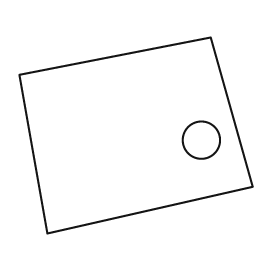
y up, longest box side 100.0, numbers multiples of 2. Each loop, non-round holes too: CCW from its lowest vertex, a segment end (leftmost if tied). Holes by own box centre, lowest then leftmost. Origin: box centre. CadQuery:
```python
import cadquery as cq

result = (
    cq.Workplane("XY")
    .moveTo(-38.0, -42.0)
    .lineTo(50.0, -22.0)
    .lineTo(32.0, 42.0)
    .lineTo(-50.0, 26.0)
    .close()
    .moveTo(28.0, -2.0)
    .circle(8.0)
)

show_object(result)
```